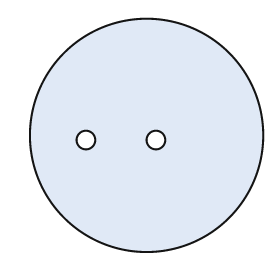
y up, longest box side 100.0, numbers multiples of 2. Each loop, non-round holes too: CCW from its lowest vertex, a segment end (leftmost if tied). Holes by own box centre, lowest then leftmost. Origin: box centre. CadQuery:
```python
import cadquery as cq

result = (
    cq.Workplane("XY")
    .moveTo(0.0, 0.0)
    .circle(50.0)
    .moveTo(-26.0, -2.0)
    .circle(4.0)
    .moveTo(4.0, -2.0)
    .circle(4.0)
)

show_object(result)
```